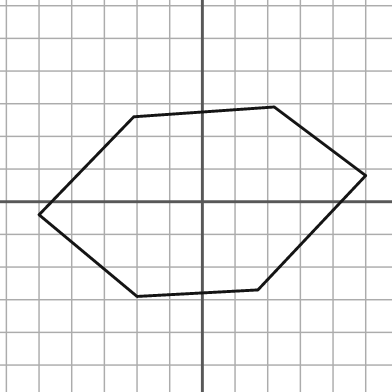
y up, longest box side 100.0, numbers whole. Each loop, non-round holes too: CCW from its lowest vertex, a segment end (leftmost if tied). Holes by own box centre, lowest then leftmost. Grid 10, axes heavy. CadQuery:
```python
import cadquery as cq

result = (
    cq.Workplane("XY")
    .moveTo(-20.0, -29.0)
    .lineTo(17.0, -27.0)
    .lineTo(50.0, 8.0)
    .lineTo(22.0, 29.0)
    .lineTo(-21.0, 26.0)
    .lineTo(-50.0, -4.0)
    .close()
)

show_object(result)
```